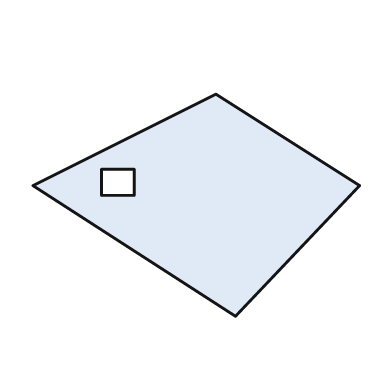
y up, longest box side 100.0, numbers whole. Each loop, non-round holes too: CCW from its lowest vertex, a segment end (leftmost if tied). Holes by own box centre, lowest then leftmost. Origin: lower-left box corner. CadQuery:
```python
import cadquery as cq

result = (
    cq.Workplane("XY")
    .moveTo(62.0, 0.0)
    .lineTo(100.0, 40.0)
    .lineTo(56.0, 68.0)
    .lineTo(0.0, 40.0)
    .close()
    .moveTo(21.0, 37.0)
    .lineTo(31.0, 37.0)
    .lineTo(31.0, 45.0)
    .lineTo(21.0, 45.0)
    .close()
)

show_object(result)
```